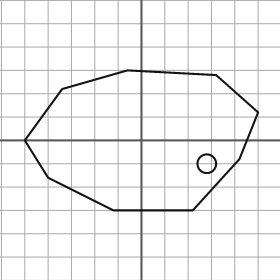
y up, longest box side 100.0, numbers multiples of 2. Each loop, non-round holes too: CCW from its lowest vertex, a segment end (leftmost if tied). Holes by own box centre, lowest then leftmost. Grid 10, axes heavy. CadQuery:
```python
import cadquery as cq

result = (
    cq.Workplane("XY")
    .moveTo(-12.0, -30.0)
    .lineTo(22.0, -30.0)
    .lineTo(42.0, -8.0)
    .lineTo(50.0, 12.0)
    .lineTo(32.0, 28.0)
    .lineTo(-6.0, 30.0)
    .lineTo(-34.0, 22.0)
    .lineTo(-50.0, 0.0)
    .lineTo(-40.0, -16.0)
    .close()
    .moveTo(28.0, -10.0)
    .circle(4.0)
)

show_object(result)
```